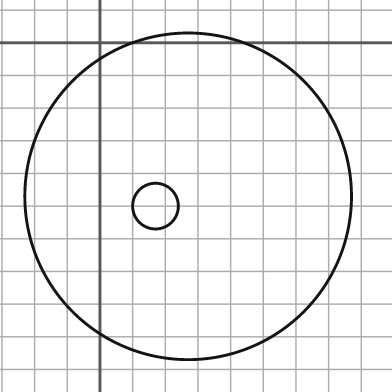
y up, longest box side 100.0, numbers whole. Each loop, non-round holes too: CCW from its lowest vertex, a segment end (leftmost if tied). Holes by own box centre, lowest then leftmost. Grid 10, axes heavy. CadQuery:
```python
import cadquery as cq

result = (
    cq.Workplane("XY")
    .moveTo(27.0, -47.0)
    .circle(50.0)
    .moveTo(17.0, -50.0)
    .circle(7.0)
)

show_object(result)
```